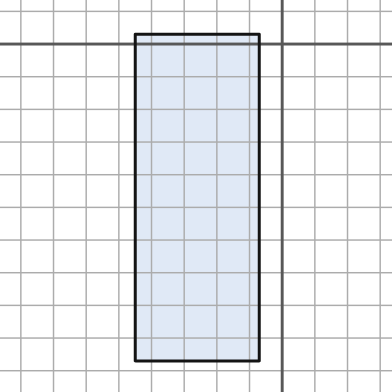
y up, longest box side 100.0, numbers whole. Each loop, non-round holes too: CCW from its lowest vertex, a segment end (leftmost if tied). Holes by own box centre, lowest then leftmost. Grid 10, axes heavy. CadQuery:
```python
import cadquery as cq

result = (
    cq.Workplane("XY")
    .moveTo(-45.0, -97.0)
    .lineTo(-7.0, -97.0)
    .lineTo(-7.0, 3.0)
    .lineTo(-45.0, 3.0)
    .close()
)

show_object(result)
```